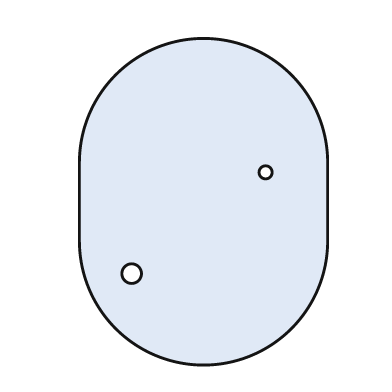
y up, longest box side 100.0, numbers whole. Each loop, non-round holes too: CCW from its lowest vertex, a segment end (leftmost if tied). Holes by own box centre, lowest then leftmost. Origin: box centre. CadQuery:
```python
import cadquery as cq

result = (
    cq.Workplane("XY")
    .moveTo(-38.0, -12.0)
    .threePointArc((0.0, -50.0), (38.0, -12.0))
    .lineTo(38.0, 12.0)
    .threePointArc((0.0, 50.0), (-38.0, 12.0))
    .close()
    .moveTo(-22.0, -22.0)
    .circle(3.0)
    .moveTo(19.0, 9.0)
    .circle(2.0)
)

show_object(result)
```